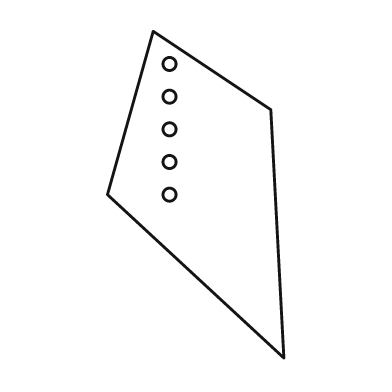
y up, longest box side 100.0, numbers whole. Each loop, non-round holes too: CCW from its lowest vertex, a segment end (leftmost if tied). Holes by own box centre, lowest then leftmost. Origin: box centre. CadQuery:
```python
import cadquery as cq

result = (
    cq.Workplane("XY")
    .moveTo(27.0, -50.0)
    .lineTo(23.0, 26.0)
    .lineTo(-13.0, 50.0)
    .lineTo(-27.0, 0.0)
    .close()
    .moveTo(-8.0, 0.0)
    .circle(2.0)
    .moveTo(-8.0, 10.0)
    .circle(2.0)
    .moveTo(-8.0, 20.0)
    .circle(2.0)
    .moveTo(-8.0, 30.0)
    .circle(2.0)
    .moveTo(-8.0, 40.0)
    .circle(2.0)
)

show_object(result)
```